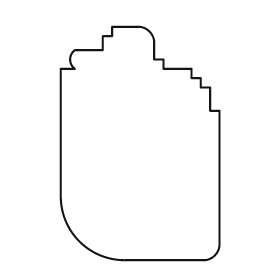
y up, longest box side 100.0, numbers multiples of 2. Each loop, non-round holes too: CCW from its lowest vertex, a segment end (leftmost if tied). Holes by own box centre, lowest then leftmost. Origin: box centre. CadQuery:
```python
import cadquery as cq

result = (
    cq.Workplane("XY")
    .moveTo(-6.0, -50.0)
    .lineTo(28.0, -50.0)
    .threePointArc((32.0, -48.0), (34.0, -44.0))
    .lineTo(34.0, 14.0)
    .lineTo(30.0, 14.0)
    .lineTo(30.0, 24.0)
    .lineTo(26.0, 24.0)
    .lineTo(26.0, 28.0)
    .lineTo(22.0, 28.0)
    .lineTo(22.0, 32.0)
    .lineTo(10.0, 32.0)
    .lineTo(10.0, 36.0)
    .lineTo(6.0, 36.0)
    .lineTo(6.0, 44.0)
    .threePointArc((4.0, 48.0), (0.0, 50.0))
    .lineTo(-12.0, 50.0)
    .lineTo(-12.0, 46.0)
    .lineTo(-16.0, 46.0)
    .lineTo(-16.0, 40.0)
    .lineTo(-28.0, 40.0)
    .threePointArc((-30.0, 36.0), (-28.0, 32.0))
    .lineTo(-34.0, 32.0)
    .lineTo(-34.0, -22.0)
    .threePointArc((-26.0, -42.0), (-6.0, -50.0))
    .close()
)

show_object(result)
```